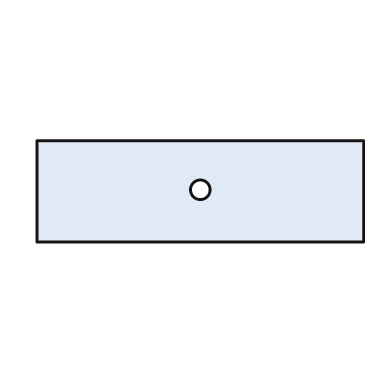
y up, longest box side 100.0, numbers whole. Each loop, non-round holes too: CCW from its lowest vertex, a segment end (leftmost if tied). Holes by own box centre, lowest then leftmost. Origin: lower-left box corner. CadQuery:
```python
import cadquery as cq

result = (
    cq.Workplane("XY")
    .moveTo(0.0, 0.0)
    .lineTo(100.0, 0.0)
    .lineTo(100.0, 31.0)
    .lineTo(0.0, 31.0)
    .close()
    .moveTo(50.0, 16.0)
    .circle(3.0)
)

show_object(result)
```